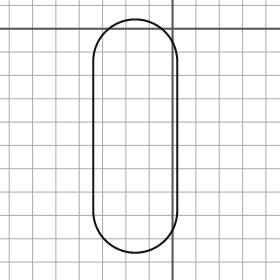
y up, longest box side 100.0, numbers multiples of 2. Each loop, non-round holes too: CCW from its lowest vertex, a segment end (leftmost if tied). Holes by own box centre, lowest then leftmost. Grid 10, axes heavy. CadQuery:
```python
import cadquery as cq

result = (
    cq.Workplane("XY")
    .moveTo(-34.0, -78.0)
    .threePointArc((-16.0, -96.0), (2.0, -78.0))
    .lineTo(2.0, -14.0)
    .threePointArc((-16.0, 4.0), (-34.0, -14.0))
    .close()
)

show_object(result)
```